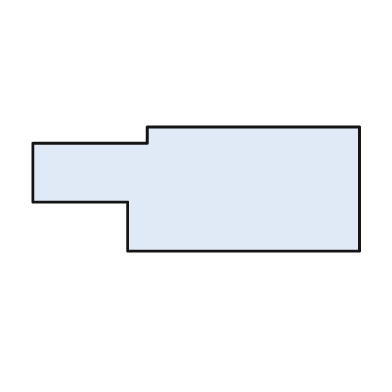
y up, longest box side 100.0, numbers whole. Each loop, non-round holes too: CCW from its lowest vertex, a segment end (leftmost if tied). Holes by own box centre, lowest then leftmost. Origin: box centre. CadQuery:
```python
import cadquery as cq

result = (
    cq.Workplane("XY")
    .moveTo(-21.0, -19.0)
    .lineTo(50.0, -19.0)
    .lineTo(50.0, 19.0)
    .lineTo(-15.0, 19.0)
    .lineTo(-15.0, 14.0)
    .lineTo(-50.0, 14.0)
    .lineTo(-50.0, -4.0)
    .lineTo(-21.0, -4.0)
    .close()
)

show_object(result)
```